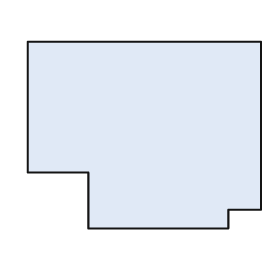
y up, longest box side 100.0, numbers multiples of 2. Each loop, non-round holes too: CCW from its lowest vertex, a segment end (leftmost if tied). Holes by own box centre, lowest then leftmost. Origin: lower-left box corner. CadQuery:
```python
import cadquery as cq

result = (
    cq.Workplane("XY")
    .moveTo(26.0, 0.0)
    .lineTo(86.0, 0.0)
    .lineTo(86.0, 8.0)
    .lineTo(100.0, 8.0)
    .lineTo(100.0, 80.0)
    .lineTo(0.0, 80.0)
    .lineTo(0.0, 24.0)
    .lineTo(26.0, 24.0)
    .close()
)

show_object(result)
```